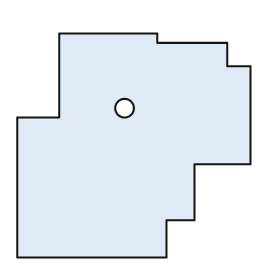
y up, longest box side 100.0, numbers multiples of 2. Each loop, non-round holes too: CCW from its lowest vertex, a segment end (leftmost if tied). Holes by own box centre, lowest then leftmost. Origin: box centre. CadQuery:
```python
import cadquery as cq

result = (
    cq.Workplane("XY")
    .moveTo(-50.0, -48.0)
    .lineTo(14.0, -48.0)
    .lineTo(14.0, -32.0)
    .lineTo(26.0, -32.0)
    .lineTo(26.0, -8.0)
    .lineTo(50.0, -8.0)
    .lineTo(50.0, 34.0)
    .lineTo(40.0, 34.0)
    .lineTo(40.0, 44.0)
    .lineTo(10.0, 44.0)
    .lineTo(10.0, 48.0)
    .lineTo(-32.0, 48.0)
    .lineTo(-32.0, 12.0)
    .lineTo(-50.0, 12.0)
    .close()
    .moveTo(-4.0, 16.0)
    .circle(4.0)
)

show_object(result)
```